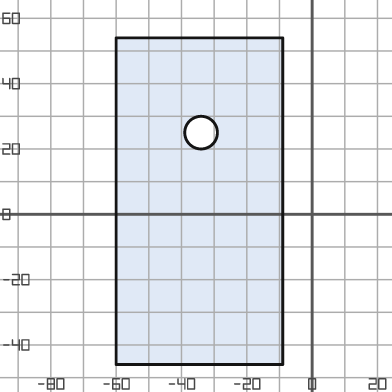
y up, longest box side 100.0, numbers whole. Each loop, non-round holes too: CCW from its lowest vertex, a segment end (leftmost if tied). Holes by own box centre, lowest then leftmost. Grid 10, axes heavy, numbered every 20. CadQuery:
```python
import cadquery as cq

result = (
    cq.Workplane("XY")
    .moveTo(-60.0, -46.0)
    .lineTo(-9.0, -46.0)
    .lineTo(-9.0, 54.0)
    .lineTo(-60.0, 54.0)
    .close()
    .moveTo(-34.0, 25.0)
    .circle(5.0)
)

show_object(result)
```